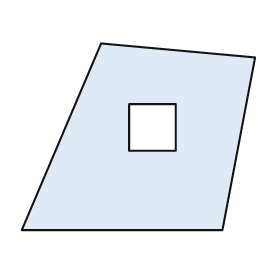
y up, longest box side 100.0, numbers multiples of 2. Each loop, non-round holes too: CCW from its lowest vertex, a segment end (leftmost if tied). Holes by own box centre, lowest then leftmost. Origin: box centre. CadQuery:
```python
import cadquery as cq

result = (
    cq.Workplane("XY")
    .moveTo(-50.0, -40.0)
    .lineTo(36.0, -40.0)
    .lineTo(50.0, 34.0)
    .lineTo(-16.0, 40.0)
    .close()
    .moveTo(-4.0, -6.0)
    .lineTo(16.0, -6.0)
    .lineTo(16.0, 14.0)
    .lineTo(-4.0, 14.0)
    .close()
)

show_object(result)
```